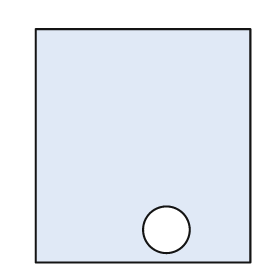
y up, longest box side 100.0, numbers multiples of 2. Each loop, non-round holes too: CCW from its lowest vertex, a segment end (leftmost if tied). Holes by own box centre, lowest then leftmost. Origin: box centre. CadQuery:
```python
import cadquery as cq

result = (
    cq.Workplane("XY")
    .moveTo(-46.0, -50.0)
    .lineTo(46.0, -50.0)
    .lineTo(46.0, 50.0)
    .lineTo(-46.0, 50.0)
    .close()
    .moveTo(10.0, -36.0)
    .circle(10.0)
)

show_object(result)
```